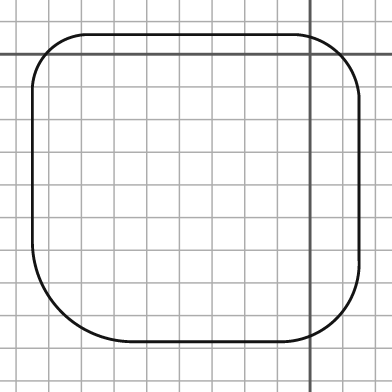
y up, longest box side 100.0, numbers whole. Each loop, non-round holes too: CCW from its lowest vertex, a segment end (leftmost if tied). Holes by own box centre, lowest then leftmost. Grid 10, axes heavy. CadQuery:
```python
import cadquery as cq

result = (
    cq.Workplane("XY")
    .moveTo(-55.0, -88.0)
    .lineTo(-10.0, -88.0)
    .threePointArc((8.0, -81.0), (15.0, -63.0))
    .lineTo(15.0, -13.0)
    .threePointArc((9.0, 0.0), (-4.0, 6.0))
    .lineTo(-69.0, 6.0)
    .threePointArc((-80.0, 1.0), (-85.0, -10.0))
    .lineTo(-85.0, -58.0)
    .threePointArc((-76.0, -79.0), (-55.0, -88.0))
    .close()
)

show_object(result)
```